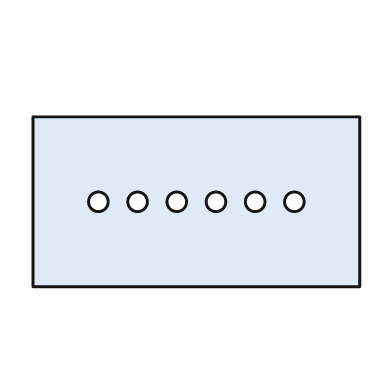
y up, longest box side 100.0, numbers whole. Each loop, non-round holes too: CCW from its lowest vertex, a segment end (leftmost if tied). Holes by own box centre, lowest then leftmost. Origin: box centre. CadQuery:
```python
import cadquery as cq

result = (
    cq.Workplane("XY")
    .moveTo(-50.0, -26.0)
    .lineTo(50.0, -26.0)
    .lineTo(50.0, 26.0)
    .lineTo(-50.0, 26.0)
    .close()
    .moveTo(-30.0, 0.0)
    .circle(3.0)
    .moveTo(-18.0, 0.0)
    .circle(3.0)
    .moveTo(-6.0, 0.0)
    .circle(3.0)
    .moveTo(6.0, 0.0)
    .circle(3.0)
    .moveTo(18.0, 0.0)
    .circle(3.0)
    .moveTo(30.0, 0.0)
    .circle(3.0)
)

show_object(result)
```